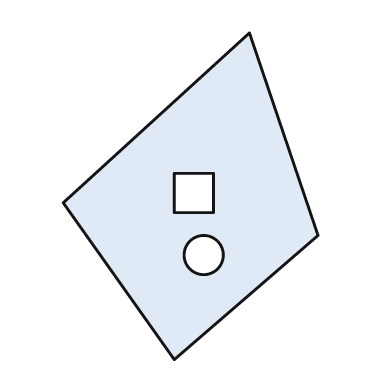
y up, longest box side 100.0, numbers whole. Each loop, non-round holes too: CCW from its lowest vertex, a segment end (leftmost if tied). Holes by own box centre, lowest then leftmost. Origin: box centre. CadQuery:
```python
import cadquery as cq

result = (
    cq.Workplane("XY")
    .moveTo(-5.0, -50.0)
    .lineTo(39.0, -12.0)
    .lineTo(18.0, 50.0)
    .lineTo(-39.0, -2.0)
    .close()
    .moveTo(4.0, -18.0)
    .circle(6.0)
    .moveTo(-5.0, -5.0)
    .lineTo(7.0, -5.0)
    .lineTo(7.0, 7.0)
    .lineTo(-5.0, 7.0)
    .close()
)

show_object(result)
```